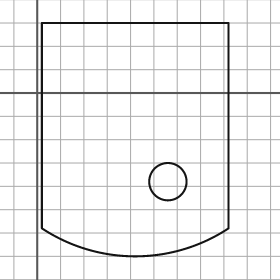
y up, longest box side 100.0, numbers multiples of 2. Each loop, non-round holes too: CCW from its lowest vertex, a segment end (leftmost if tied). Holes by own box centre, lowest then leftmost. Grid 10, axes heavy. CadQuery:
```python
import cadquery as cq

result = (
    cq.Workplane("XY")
    .moveTo(2.0, -58.0)
    .threePointArc((42.0, -70.0), (82.0, -58.0))
    .lineTo(82.0, 30.0)
    .lineTo(2.0, 30.0)
    .close()
    .moveTo(56.0, -38.0)
    .circle(8.0)
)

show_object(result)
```